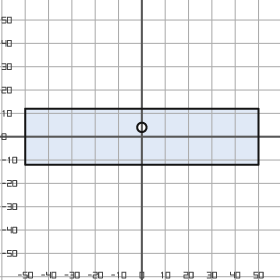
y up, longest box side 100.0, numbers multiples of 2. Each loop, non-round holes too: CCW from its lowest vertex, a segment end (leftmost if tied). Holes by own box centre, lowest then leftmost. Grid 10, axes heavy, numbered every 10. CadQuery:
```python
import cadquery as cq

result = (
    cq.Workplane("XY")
    .moveTo(-50.0, -12.0)
    .lineTo(50.0, -12.0)
    .lineTo(50.0, 12.0)
    .lineTo(-50.0, 12.0)
    .close()
    .moveTo(0.0, 4.0)
    .circle(2.0)
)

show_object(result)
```